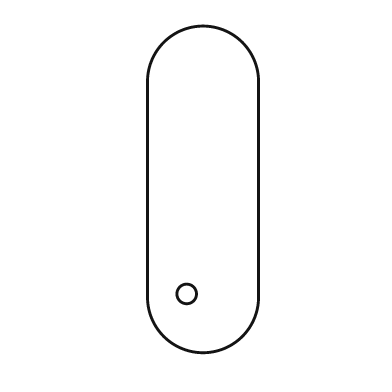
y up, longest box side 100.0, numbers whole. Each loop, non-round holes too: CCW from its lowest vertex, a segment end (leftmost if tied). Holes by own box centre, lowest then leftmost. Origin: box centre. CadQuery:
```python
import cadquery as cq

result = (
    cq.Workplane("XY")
    .moveTo(-17.0, -33.0)
    .threePointArc((0.0, -50.0), (17.0, -33.0))
    .lineTo(17.0, 33.0)
    .threePointArc((0.0, 50.0), (-17.0, 33.0))
    .close()
    .moveTo(-5.0, -32.0)
    .circle(3.0)
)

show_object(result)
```